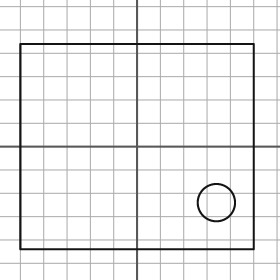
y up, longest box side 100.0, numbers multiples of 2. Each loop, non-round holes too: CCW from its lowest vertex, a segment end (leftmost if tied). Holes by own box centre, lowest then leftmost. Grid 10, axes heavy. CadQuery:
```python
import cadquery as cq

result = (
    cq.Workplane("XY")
    .moveTo(-50.0, -44.0)
    .lineTo(50.0, -44.0)
    .lineTo(50.0, 44.0)
    .lineTo(-50.0, 44.0)
    .close()
    .moveTo(34.0, -24.0)
    .circle(8.0)
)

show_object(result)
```